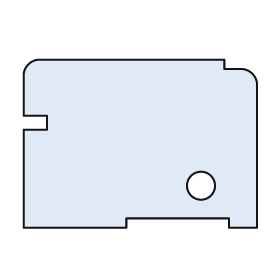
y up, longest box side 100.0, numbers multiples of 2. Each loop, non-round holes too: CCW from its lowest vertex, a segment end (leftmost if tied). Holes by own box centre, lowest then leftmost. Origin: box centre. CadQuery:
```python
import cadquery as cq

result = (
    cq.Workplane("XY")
    .moveTo(-50.0, -36.0)
    .lineTo(-6.0, -36.0)
    .lineTo(-6.0, -32.0)
    .lineTo(38.0, -32.0)
    .lineTo(38.0, -36.0)
    .lineTo(50.0, -36.0)
    .lineTo(50.0, 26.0)
    .threePointArc((48.0, 30.0), (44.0, 32.0))
    .lineTo(36.0, 32.0)
    .lineTo(36.0, 36.0)
    .lineTo(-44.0, 36.0)
    .threePointArc((-48.0, 34.0), (-50.0, 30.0))
    .lineTo(-50.0, 12.0)
    .lineTo(-40.0, 12.0)
    .lineTo(-40.0, 6.0)
    .lineTo(-50.0, 6.0)
    .close()
    .moveTo(26.0, -18.0)
    .circle(6.0)
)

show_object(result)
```